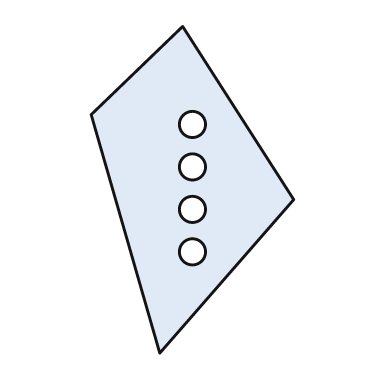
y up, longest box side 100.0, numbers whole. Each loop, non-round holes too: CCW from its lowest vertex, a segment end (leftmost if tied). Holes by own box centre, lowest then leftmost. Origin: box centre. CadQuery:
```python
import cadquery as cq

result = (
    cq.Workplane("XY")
    .moveTo(-10.0, -50.0)
    .lineTo(31.0, -3.0)
    .lineTo(-3.0, 50.0)
    .lineTo(-31.0, 23.0)
    .close()
    .moveTo(0.0, -19.0)
    .circle(4.0)
    .moveTo(0.0, -6.0)
    .circle(4.0)
    .moveTo(0.0, 7.0)
    .circle(4.0)
    .moveTo(0.0, 20.0)
    .circle(4.0)
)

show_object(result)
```